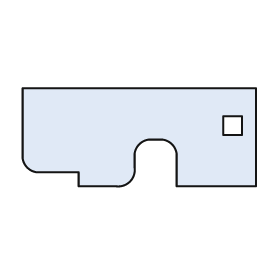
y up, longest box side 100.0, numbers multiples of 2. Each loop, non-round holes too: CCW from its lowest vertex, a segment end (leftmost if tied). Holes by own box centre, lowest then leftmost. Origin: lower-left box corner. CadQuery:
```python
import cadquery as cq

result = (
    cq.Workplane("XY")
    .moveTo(24.0, 0.0)
    .lineTo(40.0, 0.0)
    .threePointArc((46.0, 2.0), (48.0, 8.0))
    .lineTo(48.0, 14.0)
    .threePointArc((50.0, 18.0), (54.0, 20.0))
    .lineTo(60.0, 20.0)
    .threePointArc((64.0, 18.0), (66.0, 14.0))
    .lineTo(66.0, 0.0)
    .lineTo(100.0, 0.0)
    .lineTo(100.0, 42.0)
    .lineTo(0.0, 42.0)
    .lineTo(0.0, 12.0)
    .threePointArc((2.0, 8.0), (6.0, 6.0))
    .lineTo(24.0, 6.0)
    .close()
    .moveTo(86.0, 22.0)
    .lineTo(94.0, 22.0)
    .lineTo(94.0, 30.0)
    .lineTo(86.0, 30.0)
    .close()
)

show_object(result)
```